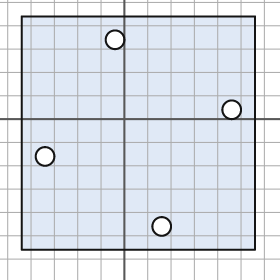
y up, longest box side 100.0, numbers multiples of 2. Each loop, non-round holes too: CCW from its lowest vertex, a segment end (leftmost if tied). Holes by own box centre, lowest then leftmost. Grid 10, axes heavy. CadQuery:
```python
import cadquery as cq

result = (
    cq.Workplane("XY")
    .moveTo(-44.0, -56.0)
    .lineTo(56.0, -56.0)
    .lineTo(56.0, 44.0)
    .lineTo(-44.0, 44.0)
    .close()
    .moveTo(16.0, -46.0)
    .circle(4.0)
    .moveTo(-34.0, -16.0)
    .circle(4.0)
    .moveTo(46.0, 4.0)
    .circle(4.0)
    .moveTo(-4.0, 34.0)
    .circle(4.0)
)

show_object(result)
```